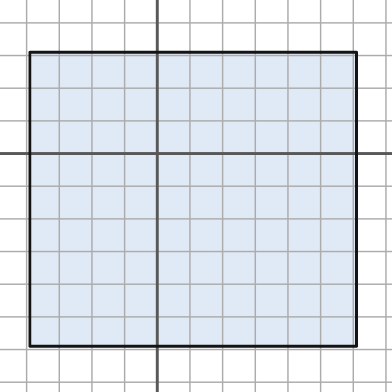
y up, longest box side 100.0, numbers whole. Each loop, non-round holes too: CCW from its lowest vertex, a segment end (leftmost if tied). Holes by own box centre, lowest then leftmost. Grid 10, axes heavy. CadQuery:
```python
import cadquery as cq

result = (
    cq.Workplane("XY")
    .moveTo(-39.0, -59.0)
    .lineTo(61.0, -59.0)
    .lineTo(61.0, 31.0)
    .lineTo(-39.0, 31.0)
    .close()
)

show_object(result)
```